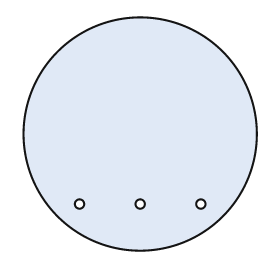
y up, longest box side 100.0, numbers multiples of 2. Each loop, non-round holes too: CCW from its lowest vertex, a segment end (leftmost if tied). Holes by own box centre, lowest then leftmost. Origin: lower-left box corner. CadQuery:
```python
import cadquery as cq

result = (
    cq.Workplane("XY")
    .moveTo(50.0, 50.0)
    .circle(50.0)
    .moveTo(24.0, 20.0)
    .circle(2.0)
    .moveTo(50.0, 20.0)
    .circle(2.0)
    .moveTo(76.0, 20.0)
    .circle(2.0)
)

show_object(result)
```